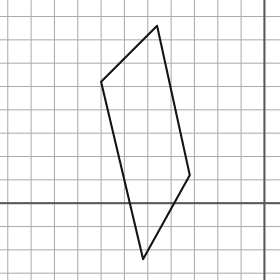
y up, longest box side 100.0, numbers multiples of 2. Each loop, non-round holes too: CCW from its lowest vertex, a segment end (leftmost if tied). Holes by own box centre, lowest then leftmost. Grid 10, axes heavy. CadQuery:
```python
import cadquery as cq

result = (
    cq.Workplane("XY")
    .moveTo(-52.0, -24.0)
    .lineTo(-32.0, 12.0)
    .lineTo(-46.0, 76.0)
    .lineTo(-70.0, 52.0)
    .close()
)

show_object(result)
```